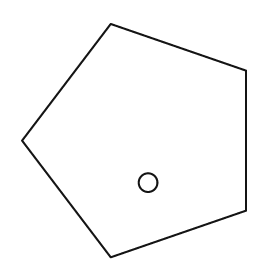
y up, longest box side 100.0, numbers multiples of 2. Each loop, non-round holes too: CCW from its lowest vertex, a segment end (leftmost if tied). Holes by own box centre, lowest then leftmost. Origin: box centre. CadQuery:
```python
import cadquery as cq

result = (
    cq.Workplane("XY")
    .moveTo(-10.0, -50.0)
    .lineTo(48.0, -30.0)
    .lineTo(48.0, 30.0)
    .lineTo(-10.0, 50.0)
    .lineTo(-48.0, 0.0)
    .close()
    .moveTo(6.0, -18.0)
    .circle(4.0)
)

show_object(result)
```